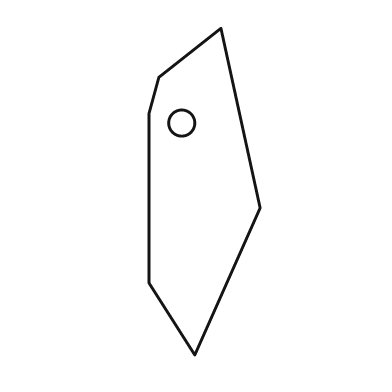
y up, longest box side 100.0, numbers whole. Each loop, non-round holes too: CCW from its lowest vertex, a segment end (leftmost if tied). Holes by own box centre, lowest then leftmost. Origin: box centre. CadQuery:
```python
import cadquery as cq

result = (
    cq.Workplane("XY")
    .moveTo(-3.0, -50.0)
    .lineTo(17.0, -5.0)
    .lineTo(5.0, 50.0)
    .lineTo(-14.0, 35.0)
    .lineTo(-17.0, 24.0)
    .lineTo(-17.0, -28.0)
    .close()
    .moveTo(-7.0, 21.0)
    .circle(4.0)
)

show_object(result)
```